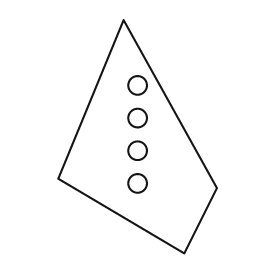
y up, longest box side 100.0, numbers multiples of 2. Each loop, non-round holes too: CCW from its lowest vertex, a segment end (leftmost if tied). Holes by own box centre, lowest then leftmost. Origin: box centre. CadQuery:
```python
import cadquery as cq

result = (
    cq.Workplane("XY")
    .moveTo(20.0, -50.0)
    .lineTo(34.0, -22.0)
    .lineTo(-6.0, 50.0)
    .lineTo(-34.0, -18.0)
    .close()
    .moveTo(0.0, -20.0)
    .circle(4.0)
    .moveTo(0.0, -6.0)
    .circle(4.0)
    .moveTo(0.0, 8.0)
    .circle(4.0)
    .moveTo(0.0, 22.0)
    .circle(4.0)
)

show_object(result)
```